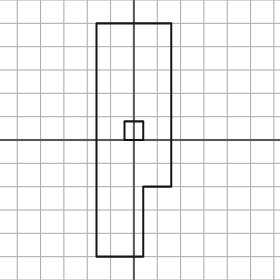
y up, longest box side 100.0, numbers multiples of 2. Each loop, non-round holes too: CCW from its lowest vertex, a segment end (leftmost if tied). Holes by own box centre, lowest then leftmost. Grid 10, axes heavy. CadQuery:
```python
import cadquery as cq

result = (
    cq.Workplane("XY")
    .moveTo(-16.0, -50.0)
    .lineTo(4.0, -50.0)
    .lineTo(4.0, -20.0)
    .lineTo(16.0, -20.0)
    .lineTo(16.0, 50.0)
    .lineTo(-16.0, 50.0)
    .close()
    .moveTo(-4.0, 0.0)
    .lineTo(4.0, 0.0)
    .lineTo(4.0, 8.0)
    .lineTo(-4.0, 8.0)
    .close()
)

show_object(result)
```